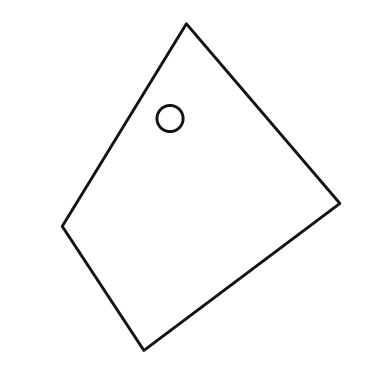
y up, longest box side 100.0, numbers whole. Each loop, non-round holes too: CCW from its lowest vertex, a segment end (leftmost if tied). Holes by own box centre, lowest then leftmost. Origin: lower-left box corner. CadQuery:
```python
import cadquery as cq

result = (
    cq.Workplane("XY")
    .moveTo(25.0, 0.0)
    .lineTo(85.0, 45.0)
    .lineTo(38.0, 100.0)
    .lineTo(0.0, 38.0)
    .close()
    .moveTo(33.0, 71.0)
    .circle(4.0)
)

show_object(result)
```